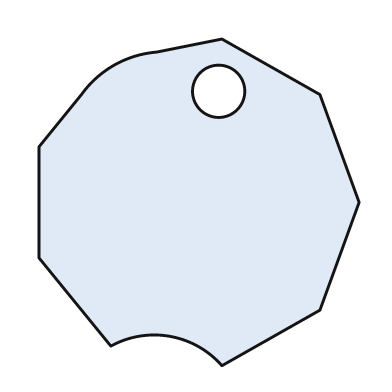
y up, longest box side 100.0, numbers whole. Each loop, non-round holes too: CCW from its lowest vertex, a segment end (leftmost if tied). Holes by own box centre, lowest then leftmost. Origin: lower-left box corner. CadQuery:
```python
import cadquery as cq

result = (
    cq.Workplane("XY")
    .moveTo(56.0, 0.0)
    .lineTo(86.0, 17.0)
    .lineTo(98.0, 50.0)
    .lineTo(86.0, 83.0)
    .lineTo(56.0, 100.0)
    .lineTo(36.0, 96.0)
    .threePointArc((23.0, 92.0), (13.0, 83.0))
    .lineTo(0.0, 67.0)
    .lineTo(0.0, 33.0)
    .lineTo(22.0, 6.0)
    .threePointArc((40.0, 9.0), (56.0, 0.0))
    .close()
    .moveTo(55.0, 84.0)
    .circle(8.0)
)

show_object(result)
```